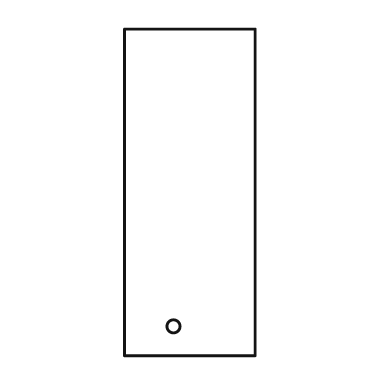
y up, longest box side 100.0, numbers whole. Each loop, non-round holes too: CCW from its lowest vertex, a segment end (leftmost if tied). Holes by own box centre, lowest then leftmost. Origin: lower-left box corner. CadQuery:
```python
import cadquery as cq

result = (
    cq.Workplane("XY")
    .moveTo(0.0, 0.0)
    .lineTo(40.0, 0.0)
    .lineTo(40.0, 100.0)
    .lineTo(0.0, 100.0)
    .close()
    .moveTo(15.0, 9.0)
    .circle(2.0)
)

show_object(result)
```